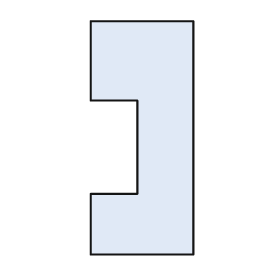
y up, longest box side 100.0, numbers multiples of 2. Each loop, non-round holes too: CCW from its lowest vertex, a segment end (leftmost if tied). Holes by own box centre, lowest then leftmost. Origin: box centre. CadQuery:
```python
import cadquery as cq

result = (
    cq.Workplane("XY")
    .moveTo(-22.0, -50.0)
    .lineTo(22.0, -50.0)
    .lineTo(22.0, 50.0)
    .lineTo(-22.0, 50.0)
    .lineTo(-22.0, 16.0)
    .lineTo(-2.0, 16.0)
    .lineTo(-2.0, -24.0)
    .lineTo(-22.0, -24.0)
    .close()
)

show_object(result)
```